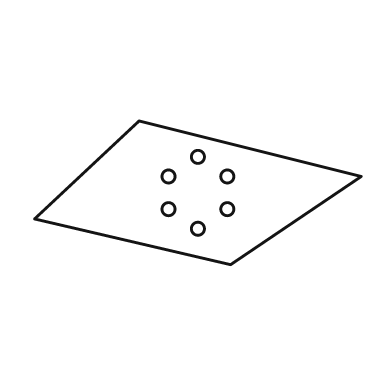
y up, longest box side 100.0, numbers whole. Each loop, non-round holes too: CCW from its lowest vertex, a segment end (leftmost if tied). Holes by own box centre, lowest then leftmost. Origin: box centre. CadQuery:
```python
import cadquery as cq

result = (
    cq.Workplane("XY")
    .moveTo(10.0, -22.0)
    .lineTo(50.0, 5.0)
    .lineTo(-18.0, 22.0)
    .lineTo(-50.0, -8.0)
    .close()
    .moveTo(0.0, -11.0)
    .circle(2.0)
    .moveTo(-9.0, -5.0)
    .circle(2.0)
    .moveTo(9.0, -5.0)
    .circle(2.0)
    .moveTo(-9.0, 5.0)
    .circle(2.0)
    .moveTo(9.0, 5.0)
    .circle(2.0)
    .moveTo(0.0, 11.0)
    .circle(2.0)
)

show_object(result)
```